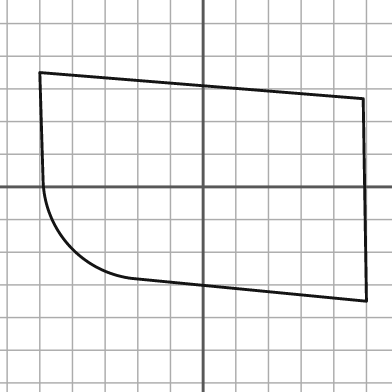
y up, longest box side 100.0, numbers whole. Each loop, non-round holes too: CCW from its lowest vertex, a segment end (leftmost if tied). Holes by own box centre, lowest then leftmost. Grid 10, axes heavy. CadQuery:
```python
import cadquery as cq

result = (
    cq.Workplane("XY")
    .moveTo(50.0, -35.0)
    .lineTo(49.0, 27.0)
    .lineTo(-50.0, 35.0)
    .lineTo(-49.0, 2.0)
    .threePointArc((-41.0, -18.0), (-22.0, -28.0))
    .close()
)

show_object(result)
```